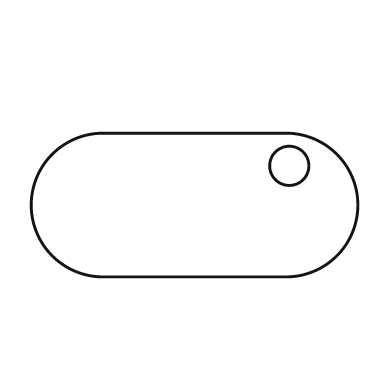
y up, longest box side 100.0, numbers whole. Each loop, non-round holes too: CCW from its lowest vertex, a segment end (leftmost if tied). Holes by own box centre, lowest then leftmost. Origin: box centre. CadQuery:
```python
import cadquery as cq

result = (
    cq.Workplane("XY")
    .moveTo(-28.0, -22.0)
    .lineTo(28.0, -22.0)
    .threePointArc((50.0, 0.0), (28.0, 22.0))
    .lineTo(-28.0, 22.0)
    .threePointArc((-50.0, 0.0), (-28.0, -22.0))
    .close()
    .moveTo(29.0, 12.0)
    .circle(6.0)
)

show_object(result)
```